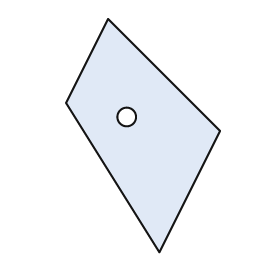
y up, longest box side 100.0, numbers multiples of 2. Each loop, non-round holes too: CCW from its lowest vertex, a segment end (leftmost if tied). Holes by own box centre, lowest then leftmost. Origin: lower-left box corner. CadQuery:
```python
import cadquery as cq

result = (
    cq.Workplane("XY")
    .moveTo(40.0, 0.0)
    .lineTo(66.0, 52.0)
    .lineTo(18.0, 100.0)
    .lineTo(0.0, 64.0)
    .close()
    .moveTo(26.0, 58.0)
    .circle(4.0)
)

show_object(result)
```